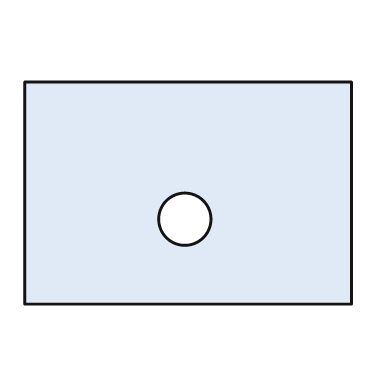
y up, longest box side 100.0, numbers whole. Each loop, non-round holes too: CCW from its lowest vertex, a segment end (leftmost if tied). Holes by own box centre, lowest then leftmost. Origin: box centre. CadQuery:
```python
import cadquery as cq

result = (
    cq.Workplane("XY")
    .moveTo(-50.0, -34.0)
    .lineTo(50.0, -34.0)
    .lineTo(50.0, 34.0)
    .lineTo(-50.0, 34.0)
    .close()
    .moveTo(-1.0, -8.0)
    .circle(8.0)
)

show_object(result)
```